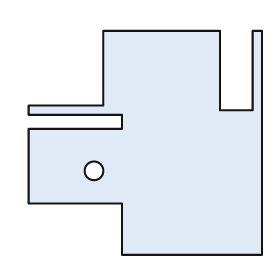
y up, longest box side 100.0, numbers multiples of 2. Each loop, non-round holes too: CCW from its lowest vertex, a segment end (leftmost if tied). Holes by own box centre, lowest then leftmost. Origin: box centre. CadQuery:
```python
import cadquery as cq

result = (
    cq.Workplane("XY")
    .moveTo(-10.0, -48.0)
    .lineTo(50.0, -48.0)
    .lineTo(50.0, 48.0)
    .lineTo(46.0, 48.0)
    .lineTo(46.0, 14.0)
    .lineTo(32.0, 14.0)
    .lineTo(32.0, 48.0)
    .lineTo(-18.0, 48.0)
    .lineTo(-18.0, 16.0)
    .lineTo(-50.0, 16.0)
    .lineTo(-50.0, 12.0)
    .lineTo(-10.0, 12.0)
    .lineTo(-10.0, 6.0)
    .lineTo(-50.0, 6.0)
    .lineTo(-50.0, -26.0)
    .lineTo(-10.0, -26.0)
    .close()
    .moveTo(-22.0, -12.0)
    .circle(4.0)
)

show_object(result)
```